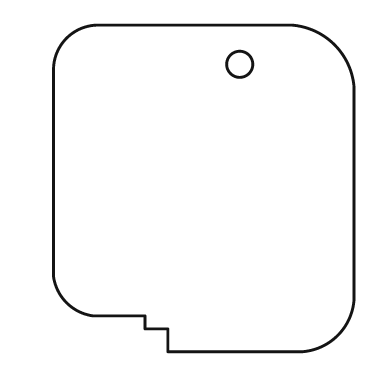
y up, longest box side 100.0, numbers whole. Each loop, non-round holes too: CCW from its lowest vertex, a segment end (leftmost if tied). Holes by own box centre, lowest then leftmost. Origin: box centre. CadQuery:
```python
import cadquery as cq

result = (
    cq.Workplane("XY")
    .moveTo(-11.0, -50.0)
    .lineTo(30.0, -50.0)
    .threePointArc((41.0, -45.0), (46.0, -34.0))
    .lineTo(46.0, 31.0)
    .threePointArc((40.0, 44.0), (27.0, 50.0))
    .lineTo(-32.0, 50.0)
    .threePointArc((-42.0, 46.0), (-46.0, 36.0))
    .lineTo(-46.0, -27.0)
    .threePointArc((-42.0, -35.0), (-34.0, -39.0))
    .lineTo(-18.0, -39.0)
    .lineTo(-18.0, -43.0)
    .lineTo(-11.0, -43.0)
    .close()
    .moveTo(11.0, 38.0)
    .circle(4.0)
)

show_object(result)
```